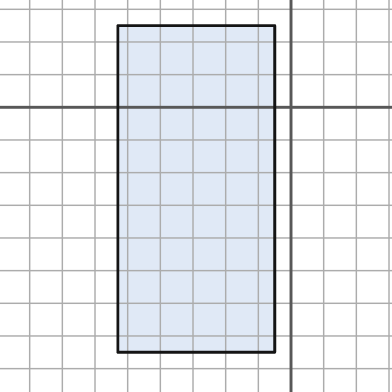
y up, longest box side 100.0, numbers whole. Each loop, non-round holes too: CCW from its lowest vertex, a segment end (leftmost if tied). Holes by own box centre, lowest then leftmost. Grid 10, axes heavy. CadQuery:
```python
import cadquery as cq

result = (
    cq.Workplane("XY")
    .moveTo(-53.0, -75.0)
    .lineTo(-5.0, -75.0)
    .lineTo(-5.0, 25.0)
    .lineTo(-53.0, 25.0)
    .close()
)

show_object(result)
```